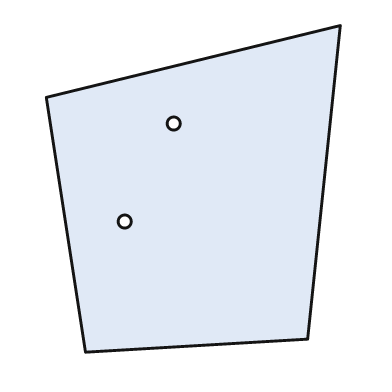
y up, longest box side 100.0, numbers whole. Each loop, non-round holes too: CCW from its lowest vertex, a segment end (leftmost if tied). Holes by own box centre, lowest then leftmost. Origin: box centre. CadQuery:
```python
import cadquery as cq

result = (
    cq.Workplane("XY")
    .moveTo(-33.0, -50.0)
    .lineTo(35.0, -46.0)
    .lineTo(45.0, 50.0)
    .lineTo(-45.0, 28.0)
    .close()
    .moveTo(-21.0, -10.0)
    .circle(2.0)
    .moveTo(-6.0, 20.0)
    .circle(2.0)
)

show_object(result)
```